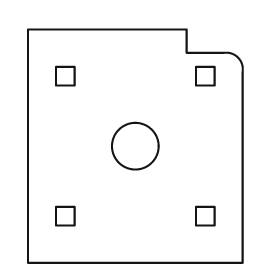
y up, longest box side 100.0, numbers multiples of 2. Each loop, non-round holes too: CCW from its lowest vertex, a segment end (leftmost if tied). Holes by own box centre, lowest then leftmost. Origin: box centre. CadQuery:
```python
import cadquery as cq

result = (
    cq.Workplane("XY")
    .moveTo(-46.0, -50.0)
    .lineTo(46.0, -50.0)
    .lineTo(46.0, 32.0)
    .threePointArc((44.0, 38.0), (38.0, 40.0))
    .lineTo(22.0, 40.0)
    .lineTo(22.0, 50.0)
    .lineTo(-46.0, 50.0)
    .close()
    .moveTo(-34.0, -34.0)
    .lineTo(-26.0, -34.0)
    .lineTo(-26.0, -26.0)
    .lineTo(-34.0, -26.0)
    .close()
    .moveTo(26.0, -34.0)
    .lineTo(34.0, -34.0)
    .lineTo(34.0, -26.0)
    .lineTo(26.0, -26.0)
    .close()
    .moveTo(0.0, 0.0)
    .circle(10.0)
    .moveTo(-34.0, 26.0)
    .lineTo(-26.0, 26.0)
    .lineTo(-26.0, 34.0)
    .lineTo(-34.0, 34.0)
    .close()
    .moveTo(26.0, 26.0)
    .lineTo(34.0, 26.0)
    .lineTo(34.0, 34.0)
    .lineTo(26.0, 34.0)
    .close()
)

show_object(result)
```